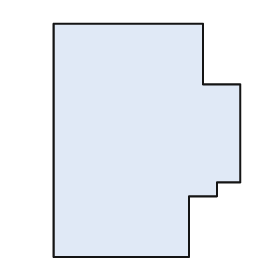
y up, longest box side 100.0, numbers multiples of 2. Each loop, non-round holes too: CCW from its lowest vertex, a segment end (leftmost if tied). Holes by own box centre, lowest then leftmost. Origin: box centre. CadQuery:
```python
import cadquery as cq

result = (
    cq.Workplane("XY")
    .moveTo(-40.0, -50.0)
    .lineTo(18.0, -50.0)
    .lineTo(18.0, -24.0)
    .lineTo(30.0, -24.0)
    .lineTo(30.0, -18.0)
    .lineTo(40.0, -18.0)
    .lineTo(40.0, 24.0)
    .lineTo(24.0, 24.0)
    .lineTo(24.0, 50.0)
    .lineTo(-40.0, 50.0)
    .close()
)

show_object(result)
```